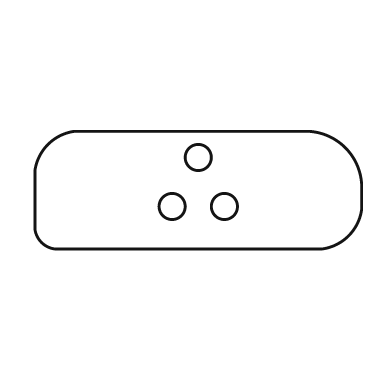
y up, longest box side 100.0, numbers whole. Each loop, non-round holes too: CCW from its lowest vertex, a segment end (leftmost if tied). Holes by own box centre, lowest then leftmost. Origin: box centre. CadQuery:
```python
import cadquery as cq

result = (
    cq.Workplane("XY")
    .moveTo(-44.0, -18.0)
    .lineTo(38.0, -18.0)
    .threePointArc((46.0, -14.0), (50.0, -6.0))
    .lineTo(50.0, 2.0)
    .threePointArc((45.0, 13.0), (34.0, 18.0))
    .lineTo(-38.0, 18.0)
    .threePointArc((-46.0, 14.0), (-50.0, 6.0))
    .lineTo(-50.0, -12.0)
    .threePointArc((-48.0, -16.0), (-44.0, -18.0))
    .close()
    .moveTo(-8.0, -5.0)
    .circle(4.0)
    .moveTo(8.0, -5.0)
    .circle(4.0)
    .moveTo(0.0, 10.0)
    .circle(4.0)
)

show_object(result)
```